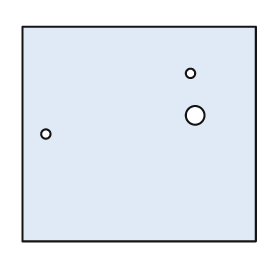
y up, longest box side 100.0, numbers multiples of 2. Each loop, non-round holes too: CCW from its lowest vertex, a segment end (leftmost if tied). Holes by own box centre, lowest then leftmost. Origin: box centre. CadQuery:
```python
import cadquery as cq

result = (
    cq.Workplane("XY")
    .moveTo(-50.0, -46.0)
    .lineTo(50.0, -46.0)
    .lineTo(50.0, 46.0)
    .lineTo(-50.0, 46.0)
    .close()
    .moveTo(-40.0, 0.0)
    .circle(2.0)
    .moveTo(24.0, 8.0)
    .circle(4.0)
    .moveTo(22.0, 26.0)
    .circle(2.0)
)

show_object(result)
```